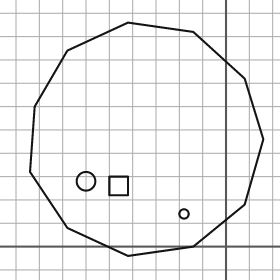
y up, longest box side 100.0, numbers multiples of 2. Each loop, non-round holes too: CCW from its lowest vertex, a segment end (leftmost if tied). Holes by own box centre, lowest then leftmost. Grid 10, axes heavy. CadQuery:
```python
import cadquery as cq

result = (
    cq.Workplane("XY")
    .moveTo(-42.0, -4.0)
    .lineTo(-14.0, 0.0)
    .lineTo(8.0, 18.0)
    .lineTo(16.0, 46.0)
    .lineTo(8.0, 72.0)
    .lineTo(-14.0, 92.0)
    .lineTo(-42.0, 96.0)
    .lineTo(-68.0, 84.0)
    .lineTo(-82.0, 60.0)
    .lineTo(-84.0, 32.0)
    .lineTo(-68.0, 8.0)
    .close()
    .moveTo(-18.0, 14.0)
    .circle(2.0)
    .moveTo(-50.0, 22.0)
    .lineTo(-42.0, 22.0)
    .lineTo(-42.0, 30.0)
    .lineTo(-50.0, 30.0)
    .close()
    .moveTo(-60.0, 28.0)
    .circle(4.0)
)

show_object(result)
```